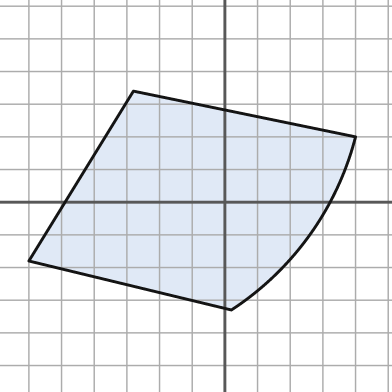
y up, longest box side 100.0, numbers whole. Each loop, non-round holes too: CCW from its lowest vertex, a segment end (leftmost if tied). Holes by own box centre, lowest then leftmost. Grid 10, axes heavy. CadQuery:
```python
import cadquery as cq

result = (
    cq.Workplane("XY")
    .moveTo(2.0, -33.0)
    .threePointArc((26.0, -10.0), (40.0, 20.0))
    .lineTo(-28.0, 34.0)
    .lineTo(-60.0, -18.0)
    .close()
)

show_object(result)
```